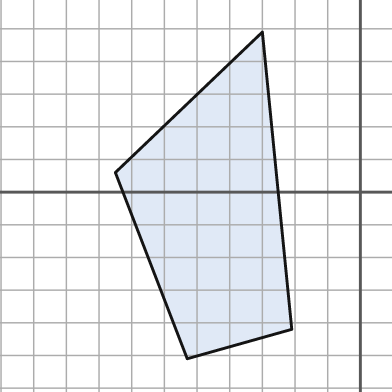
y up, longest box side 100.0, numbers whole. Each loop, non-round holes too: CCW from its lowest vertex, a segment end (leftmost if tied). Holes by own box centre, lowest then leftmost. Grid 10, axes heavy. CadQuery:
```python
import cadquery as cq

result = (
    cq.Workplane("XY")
    .moveTo(-53.0, -51.0)
    .lineTo(-21.0, -42.0)
    .lineTo(-30.0, 49.0)
    .lineTo(-75.0, 6.0)
    .close()
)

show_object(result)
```